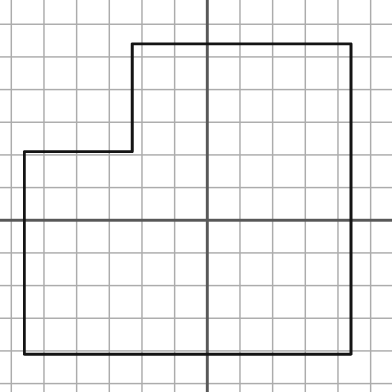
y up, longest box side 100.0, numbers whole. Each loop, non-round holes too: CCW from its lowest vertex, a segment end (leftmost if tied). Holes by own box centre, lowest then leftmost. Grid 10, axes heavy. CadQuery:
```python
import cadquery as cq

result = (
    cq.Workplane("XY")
    .moveTo(-56.0, -41.0)
    .lineTo(44.0, -41.0)
    .lineTo(44.0, 54.0)
    .lineTo(-23.0, 54.0)
    .lineTo(-23.0, 21.0)
    .lineTo(-56.0, 21.0)
    .close()
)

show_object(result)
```